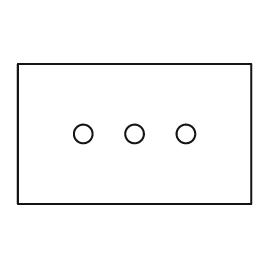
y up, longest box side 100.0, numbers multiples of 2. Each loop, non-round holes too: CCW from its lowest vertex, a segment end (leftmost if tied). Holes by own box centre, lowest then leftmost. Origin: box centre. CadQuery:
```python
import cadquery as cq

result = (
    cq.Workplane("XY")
    .moveTo(-50.0, -30.0)
    .lineTo(50.0, -30.0)
    .lineTo(50.0, 30.0)
    .lineTo(-50.0, 30.0)
    .close()
    .moveTo(-22.0, 0.0)
    .circle(4.0)
    .moveTo(0.0, 0.0)
    .circle(4.0)
    .moveTo(22.0, 0.0)
    .circle(4.0)
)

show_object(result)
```